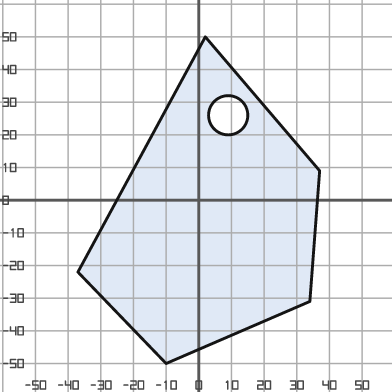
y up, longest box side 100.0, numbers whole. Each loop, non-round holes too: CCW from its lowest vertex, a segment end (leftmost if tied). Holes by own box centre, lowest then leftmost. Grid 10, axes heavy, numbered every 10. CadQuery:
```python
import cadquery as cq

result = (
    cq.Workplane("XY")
    .moveTo(-10.0, -50.0)
    .lineTo(34.0, -31.0)
    .lineTo(37.0, 9.0)
    .lineTo(2.0, 50.0)
    .lineTo(-37.0, -22.0)
    .close()
    .moveTo(9.0, 26.0)
    .circle(6.0)
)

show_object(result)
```